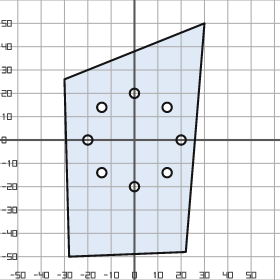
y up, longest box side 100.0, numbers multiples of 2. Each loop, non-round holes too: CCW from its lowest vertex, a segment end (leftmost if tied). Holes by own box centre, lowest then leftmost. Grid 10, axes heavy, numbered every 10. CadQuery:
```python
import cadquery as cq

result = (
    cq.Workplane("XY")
    .moveTo(-28.0, -50.0)
    .lineTo(22.0, -48.0)
    .lineTo(30.0, 50.0)
    .lineTo(-30.0, 26.0)
    .close()
    .moveTo(0.0, -20.0)
    .circle(2.0)
    .moveTo(-14.0, -14.0)
    .circle(2.0)
    .moveTo(14.0, -14.0)
    .circle(2.0)
    .moveTo(-20.0, 0.0)
    .circle(2.0)
    .moveTo(20.0, 0.0)
    .circle(2.0)
    .moveTo(-14.0, 14.0)
    .circle(2.0)
    .moveTo(14.0, 14.0)
    .circle(2.0)
    .moveTo(0.0, 20.0)
    .circle(2.0)
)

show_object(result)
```